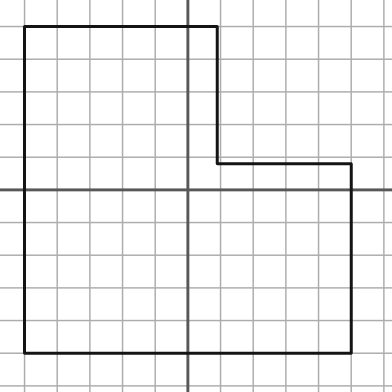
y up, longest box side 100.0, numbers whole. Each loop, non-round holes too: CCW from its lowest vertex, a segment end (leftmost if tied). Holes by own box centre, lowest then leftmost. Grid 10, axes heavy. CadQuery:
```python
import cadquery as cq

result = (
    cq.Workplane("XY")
    .moveTo(-50.0, -50.0)
    .lineTo(50.0, -50.0)
    .lineTo(50.0, 8.0)
    .lineTo(9.0, 8.0)
    .lineTo(9.0, 50.0)
    .lineTo(-50.0, 50.0)
    .close()
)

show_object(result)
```